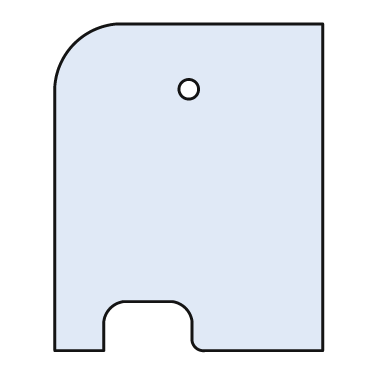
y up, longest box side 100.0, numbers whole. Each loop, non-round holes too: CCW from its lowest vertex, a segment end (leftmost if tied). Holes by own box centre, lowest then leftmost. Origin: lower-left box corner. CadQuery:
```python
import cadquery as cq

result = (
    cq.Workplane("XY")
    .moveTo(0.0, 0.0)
    .lineTo(15.0, 0.0)
    .lineTo(15.0, 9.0)
    .threePointArc((17.0, 13.0), (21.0, 15.0))
    .lineTo(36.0, 15.0)
    .threePointArc((40.0, 13.0), (42.0, 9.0))
    .lineTo(42.0, 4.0)
    .threePointArc((43.0, 1.0), (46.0, 0.0))
    .lineTo(82.0, 0.0)
    .lineTo(82.0, 100.0)
    .lineTo(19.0, 100.0)
    .threePointArc((6.0, 94.0), (0.0, 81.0))
    .close()
    .moveTo(41.0, 80.0)
    .circle(3.0)
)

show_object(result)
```